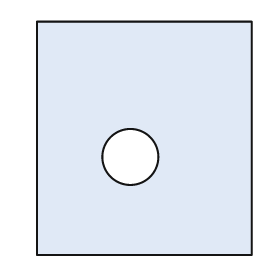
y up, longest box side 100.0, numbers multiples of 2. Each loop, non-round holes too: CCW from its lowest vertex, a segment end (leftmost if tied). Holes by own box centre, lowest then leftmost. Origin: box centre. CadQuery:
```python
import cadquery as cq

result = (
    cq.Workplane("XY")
    .moveTo(-46.0, -50.0)
    .lineTo(46.0, -50.0)
    .lineTo(46.0, 50.0)
    .lineTo(-46.0, 50.0)
    .close()
    .moveTo(-6.0, -8.0)
    .circle(12.0)
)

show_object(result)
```